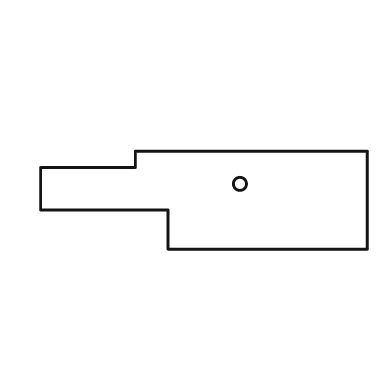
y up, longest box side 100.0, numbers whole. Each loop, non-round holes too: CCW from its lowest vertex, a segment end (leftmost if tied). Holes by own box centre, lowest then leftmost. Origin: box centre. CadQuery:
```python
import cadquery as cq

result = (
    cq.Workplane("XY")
    .moveTo(-11.0, -15.0)
    .lineTo(50.0, -15.0)
    .lineTo(50.0, 15.0)
    .lineTo(-21.0, 15.0)
    .lineTo(-21.0, 10.0)
    .lineTo(-50.0, 10.0)
    .lineTo(-50.0, -3.0)
    .lineTo(-11.0, -3.0)
    .close()
    .moveTo(11.0, 5.0)
    .circle(2.0)
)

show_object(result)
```